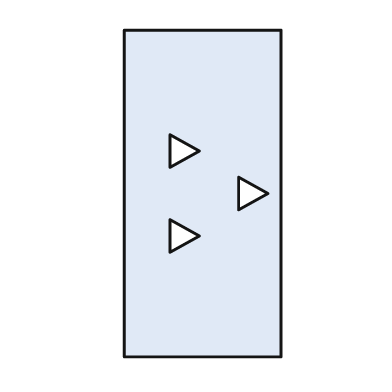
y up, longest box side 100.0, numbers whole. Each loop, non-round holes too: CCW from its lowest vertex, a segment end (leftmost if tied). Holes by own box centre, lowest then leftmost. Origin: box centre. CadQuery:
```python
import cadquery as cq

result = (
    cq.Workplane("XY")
    .moveTo(-24.0, -50.0)
    .lineTo(24.0, -50.0)
    .lineTo(24.0, 50.0)
    .lineTo(-24.0, 50.0)
    .close()
    .moveTo(-10.0, -18.0)
    .lineTo(-1.0, -13.0)
    .lineTo(-10.0, -8.0)
    .close()
    .moveTo(11.0, -5.0)
    .lineTo(20.0, 0.0)
    .lineTo(11.0, 5.0)
    .close()
    .moveTo(-10.0, 8.0)
    .lineTo(-1.0, 13.0)
    .lineTo(-10.0, 18.0)
    .close()
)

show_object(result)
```